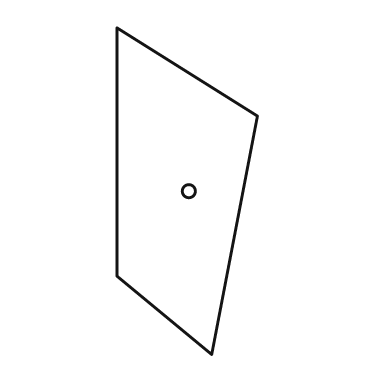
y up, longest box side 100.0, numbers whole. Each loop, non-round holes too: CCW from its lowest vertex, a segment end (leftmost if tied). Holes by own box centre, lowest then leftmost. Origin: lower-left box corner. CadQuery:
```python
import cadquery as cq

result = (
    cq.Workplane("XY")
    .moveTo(29.0, 0.0)
    .lineTo(43.0, 73.0)
    .lineTo(0.0, 100.0)
    .lineTo(0.0, 24.0)
    .close()
    .moveTo(22.0, 50.0)
    .circle(2.0)
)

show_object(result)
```